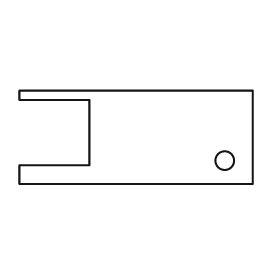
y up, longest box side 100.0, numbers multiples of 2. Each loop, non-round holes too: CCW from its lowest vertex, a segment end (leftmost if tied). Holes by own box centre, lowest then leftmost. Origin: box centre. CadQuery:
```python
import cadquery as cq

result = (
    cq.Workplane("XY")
    .moveTo(-50.0, -20.0)
    .lineTo(50.0, -20.0)
    .lineTo(50.0, 20.0)
    .lineTo(-50.0, 20.0)
    .lineTo(-50.0, 16.0)
    .lineTo(-20.0, 16.0)
    .lineTo(-20.0, -12.0)
    .lineTo(-50.0, -12.0)
    .close()
    .moveTo(38.0, -10.0)
    .circle(4.0)
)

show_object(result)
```